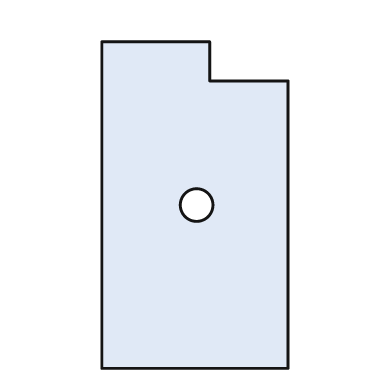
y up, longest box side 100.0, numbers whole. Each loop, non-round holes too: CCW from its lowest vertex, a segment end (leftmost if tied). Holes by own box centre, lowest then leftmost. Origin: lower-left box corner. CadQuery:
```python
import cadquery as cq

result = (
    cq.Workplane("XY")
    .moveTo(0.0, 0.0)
    .lineTo(57.0, 0.0)
    .lineTo(57.0, 88.0)
    .lineTo(33.0, 88.0)
    .lineTo(33.0, 100.0)
    .lineTo(0.0, 100.0)
    .close()
    .moveTo(29.0, 50.0)
    .circle(5.0)
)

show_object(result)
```